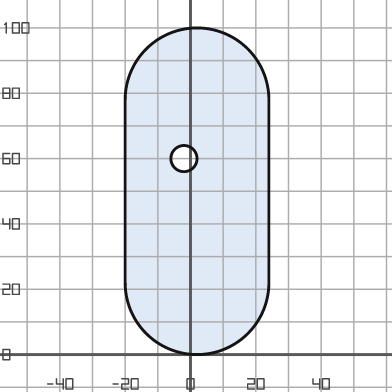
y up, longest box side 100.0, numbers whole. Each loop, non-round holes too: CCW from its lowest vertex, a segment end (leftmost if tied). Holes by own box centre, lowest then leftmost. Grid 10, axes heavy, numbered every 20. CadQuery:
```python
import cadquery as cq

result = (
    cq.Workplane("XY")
    .moveTo(-20.0, 22.0)
    .threePointArc((2.0, 0.0), (24.0, 22.0))
    .lineTo(24.0, 78.0)
    .threePointArc((2.0, 100.0), (-20.0, 78.0))
    .close()
    .moveTo(-2.0, 60.0)
    .circle(4.0)
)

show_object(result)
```